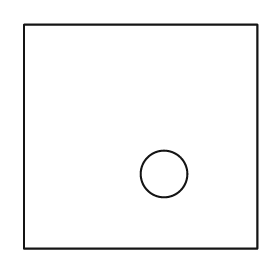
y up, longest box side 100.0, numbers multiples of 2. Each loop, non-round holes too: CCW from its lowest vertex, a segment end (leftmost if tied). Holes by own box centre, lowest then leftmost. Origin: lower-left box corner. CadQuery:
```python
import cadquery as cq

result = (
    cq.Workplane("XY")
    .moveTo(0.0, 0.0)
    .lineTo(100.0, 0.0)
    .lineTo(100.0, 96.0)
    .lineTo(0.0, 96.0)
    .close()
    .moveTo(60.0, 32.0)
    .circle(10.0)
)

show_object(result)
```